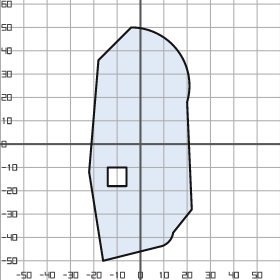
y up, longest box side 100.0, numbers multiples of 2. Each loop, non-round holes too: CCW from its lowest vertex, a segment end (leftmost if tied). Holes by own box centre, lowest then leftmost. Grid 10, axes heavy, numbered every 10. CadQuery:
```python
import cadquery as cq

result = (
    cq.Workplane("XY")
    .moveTo(-16.0, -50.0)
    .lineTo(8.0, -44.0)
    .threePointArc((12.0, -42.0), (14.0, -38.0))
    .lineTo(22.0, -28.0)
    .lineTo(20.0, 18.0)
    .threePointArc((16.0, 40.0), (-4.0, 50.0))
    .lineTo(-18.0, 36.0)
    .lineTo(-22.0, -12.0)
    .close()
    .moveTo(-14.0, -18.0)
    .lineTo(-6.0, -18.0)
    .lineTo(-6.0, -10.0)
    .lineTo(-14.0, -10.0)
    .close()
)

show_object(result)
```